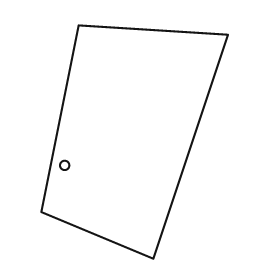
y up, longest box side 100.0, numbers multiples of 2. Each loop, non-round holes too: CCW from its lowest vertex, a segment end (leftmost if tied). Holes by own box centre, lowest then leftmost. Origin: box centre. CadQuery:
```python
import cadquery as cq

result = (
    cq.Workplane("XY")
    .moveTo(8.0, -50.0)
    .lineTo(40.0, 46.0)
    .lineTo(-24.0, 50.0)
    .lineTo(-40.0, -30.0)
    .close()
    .moveTo(-30.0, -10.0)
    .circle(2.0)
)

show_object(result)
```